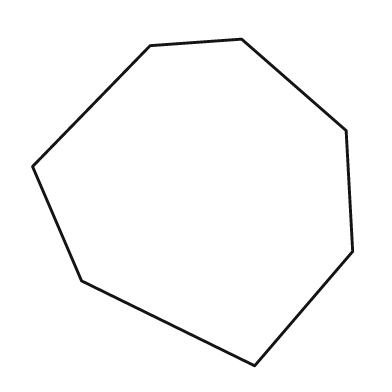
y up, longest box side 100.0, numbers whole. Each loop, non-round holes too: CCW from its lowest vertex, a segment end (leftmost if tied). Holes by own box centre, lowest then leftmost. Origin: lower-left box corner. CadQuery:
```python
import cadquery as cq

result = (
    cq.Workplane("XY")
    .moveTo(68.0, 0.0)
    .lineTo(98.0, 35.0)
    .lineTo(96.0, 72.0)
    .lineTo(64.0, 100.0)
    .lineTo(36.0, 98.0)
    .lineTo(0.0, 61.0)
    .lineTo(15.0, 26.0)
    .close()
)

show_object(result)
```